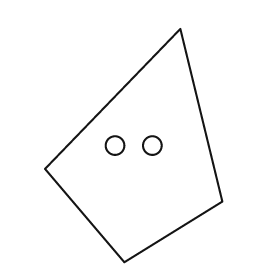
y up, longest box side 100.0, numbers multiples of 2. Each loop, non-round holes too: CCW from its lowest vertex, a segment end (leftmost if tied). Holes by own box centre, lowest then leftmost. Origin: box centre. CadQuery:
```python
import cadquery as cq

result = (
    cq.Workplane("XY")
    .moveTo(-4.0, -50.0)
    .lineTo(38.0, -24.0)
    .lineTo(20.0, 50.0)
    .lineTo(-38.0, -10.0)
    .close()
    .moveTo(-8.0, 0.0)
    .circle(4.0)
    .moveTo(8.0, 0.0)
    .circle(4.0)
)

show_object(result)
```